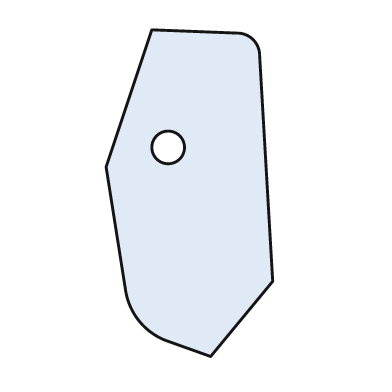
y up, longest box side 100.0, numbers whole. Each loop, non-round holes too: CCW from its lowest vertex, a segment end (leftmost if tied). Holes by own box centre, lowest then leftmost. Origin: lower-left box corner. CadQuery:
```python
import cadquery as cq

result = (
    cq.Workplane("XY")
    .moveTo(32.0, 0.0)
    .lineTo(51.0, 23.0)
    .lineTo(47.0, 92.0)
    .threePointArc((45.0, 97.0), (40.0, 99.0))
    .lineTo(14.0, 100.0)
    .lineTo(0.0, 58.0)
    .lineTo(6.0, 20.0)
    .threePointArc((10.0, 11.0), (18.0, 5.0))
    .close()
    .moveTo(19.0, 64.0)
    .circle(5.0)
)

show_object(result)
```